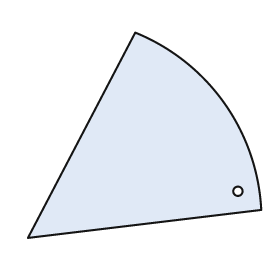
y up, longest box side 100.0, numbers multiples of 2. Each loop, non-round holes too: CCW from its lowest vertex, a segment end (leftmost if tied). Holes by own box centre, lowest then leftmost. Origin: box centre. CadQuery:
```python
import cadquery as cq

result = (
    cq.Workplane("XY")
    .moveTo(-50.0, -44.0)
    .lineTo(50.0, -32.0)
    .threePointArc((34.0, 14.0), (-4.0, 44.0))
    .close()
    .moveTo(40.0, -24.0)
    .circle(2.0)
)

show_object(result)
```